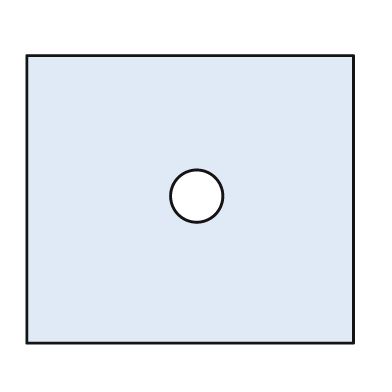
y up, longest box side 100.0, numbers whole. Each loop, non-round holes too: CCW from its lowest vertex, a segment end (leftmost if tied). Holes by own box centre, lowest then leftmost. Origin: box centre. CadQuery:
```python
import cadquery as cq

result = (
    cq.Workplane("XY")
    .moveTo(-50.0, -44.0)
    .lineTo(50.0, -44.0)
    .lineTo(50.0, 44.0)
    .lineTo(-50.0, 44.0)
    .close()
    .moveTo(2.0, 1.0)
    .circle(8.0)
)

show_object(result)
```